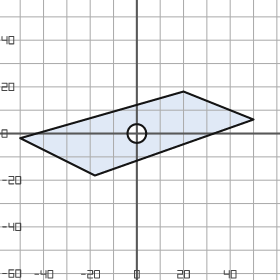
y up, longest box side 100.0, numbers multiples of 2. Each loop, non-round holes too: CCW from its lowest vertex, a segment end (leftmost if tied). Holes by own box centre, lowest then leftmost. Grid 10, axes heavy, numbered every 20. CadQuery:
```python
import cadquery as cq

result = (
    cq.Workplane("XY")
    .moveTo(-18.0, -18.0)
    .lineTo(50.0, 6.0)
    .lineTo(20.0, 18.0)
    .lineTo(-50.0, -2.0)
    .close()
    .moveTo(0.0, 0.0)
    .circle(4.0)
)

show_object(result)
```